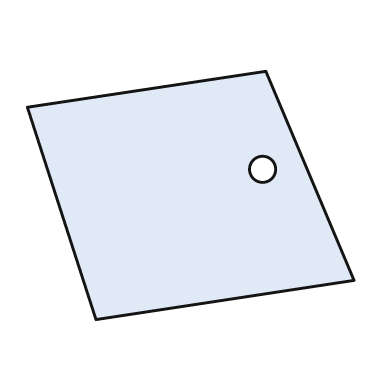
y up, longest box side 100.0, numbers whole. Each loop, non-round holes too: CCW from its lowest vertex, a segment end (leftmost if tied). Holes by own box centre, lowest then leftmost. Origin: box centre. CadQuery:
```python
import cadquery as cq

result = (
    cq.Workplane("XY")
    .moveTo(-29.0, -38.0)
    .lineTo(50.0, -26.0)
    .lineTo(23.0, 38.0)
    .lineTo(-50.0, 27.0)
    .close()
    .moveTo(22.0, 8.0)
    .circle(4.0)
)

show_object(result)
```